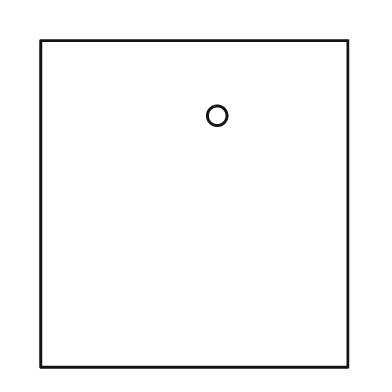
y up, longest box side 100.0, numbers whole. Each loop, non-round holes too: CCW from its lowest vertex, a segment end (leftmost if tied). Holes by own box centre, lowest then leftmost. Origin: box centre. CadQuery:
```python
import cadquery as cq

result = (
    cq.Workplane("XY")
    .moveTo(-47.0, -50.0)
    .lineTo(47.0, -50.0)
    .lineTo(47.0, 50.0)
    .lineTo(-47.0, 50.0)
    .close()
    .moveTo(7.0, 27.0)
    .circle(3.0)
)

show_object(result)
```